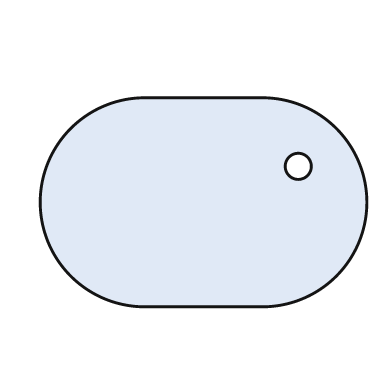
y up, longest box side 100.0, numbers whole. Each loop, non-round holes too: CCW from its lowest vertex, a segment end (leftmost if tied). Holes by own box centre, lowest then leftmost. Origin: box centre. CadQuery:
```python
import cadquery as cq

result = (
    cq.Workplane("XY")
    .moveTo(-18.0, -32.0)
    .lineTo(18.0, -32.0)
    .threePointArc((50.0, 0.0), (18.0, 32.0))
    .lineTo(-18.0, 32.0)
    .threePointArc((-50.0, 0.0), (-18.0, -32.0))
    .close()
    .moveTo(29.0, 11.0)
    .circle(4.0)
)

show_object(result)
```